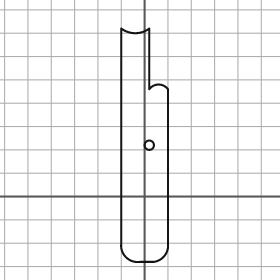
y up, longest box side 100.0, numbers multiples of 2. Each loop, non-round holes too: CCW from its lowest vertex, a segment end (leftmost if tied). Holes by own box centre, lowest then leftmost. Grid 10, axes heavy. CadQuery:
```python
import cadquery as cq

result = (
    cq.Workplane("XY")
    .moveTo(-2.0, -28.0)
    .lineTo(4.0, -28.0)
    .threePointArc((8.0, -26.0), (10.0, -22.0))
    .lineTo(10.0, 46.0)
    .threePointArc((6.0, 48.0), (2.0, 46.0))
    .lineTo(2.0, 72.0)
    .threePointArc((-4.0, 70.0), (-10.0, 72.0))
    .lineTo(-10.0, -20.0)
    .threePointArc((-8.0, -26.0), (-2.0, -28.0))
    .close()
    .moveTo(2.0, 22.0)
    .circle(2.0)
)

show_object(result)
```